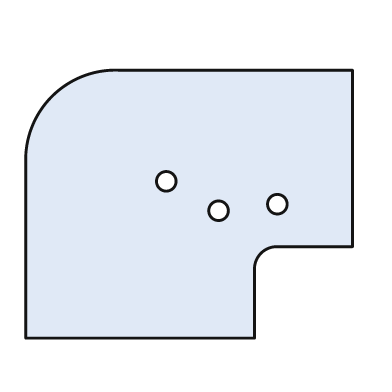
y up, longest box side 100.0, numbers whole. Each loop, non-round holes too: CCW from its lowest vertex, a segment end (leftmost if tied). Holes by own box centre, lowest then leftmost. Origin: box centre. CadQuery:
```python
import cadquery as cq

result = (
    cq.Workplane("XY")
    .moveTo(-50.0, -41.0)
    .lineTo(20.0, -41.0)
    .lineTo(20.0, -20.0)
    .threePointArc((22.0, -15.0), (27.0, -13.0))
    .lineTo(50.0, -13.0)
    .lineTo(50.0, 41.0)
    .lineTo(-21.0, 41.0)
    .threePointArc((-42.0, 33.0), (-50.0, 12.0))
    .close()
    .moveTo(9.0, -2.0)
    .circle(3.0)
    .moveTo(27.0, 0.0)
    .circle(3.0)
    .moveTo(-7.0, 7.0)
    .circle(3.0)
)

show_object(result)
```